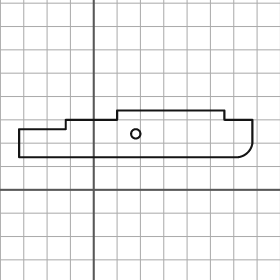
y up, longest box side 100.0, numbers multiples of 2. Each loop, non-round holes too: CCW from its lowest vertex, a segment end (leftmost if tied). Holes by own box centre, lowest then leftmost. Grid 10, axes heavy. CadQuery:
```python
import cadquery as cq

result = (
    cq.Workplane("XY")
    .moveTo(-32.0, 14.0)
    .lineTo(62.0, 14.0)
    .threePointArc((66.0, 16.0), (68.0, 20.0))
    .lineTo(68.0, 30.0)
    .lineTo(56.0, 30.0)
    .lineTo(56.0, 34.0)
    .lineTo(10.0, 34.0)
    .lineTo(10.0, 30.0)
    .lineTo(-12.0, 30.0)
    .lineTo(-12.0, 26.0)
    .lineTo(-32.0, 26.0)
    .close()
    .moveTo(18.0, 24.0)
    .circle(2.0)
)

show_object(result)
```